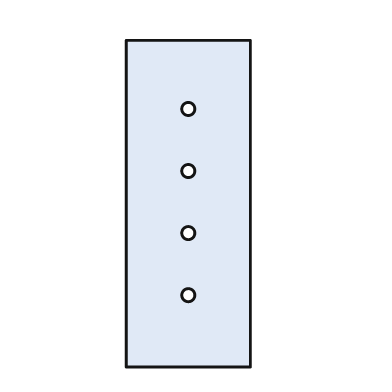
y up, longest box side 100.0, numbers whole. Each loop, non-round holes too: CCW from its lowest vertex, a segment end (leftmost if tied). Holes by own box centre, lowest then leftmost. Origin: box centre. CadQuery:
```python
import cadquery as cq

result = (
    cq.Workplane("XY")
    .moveTo(-19.0, -50.0)
    .lineTo(19.0, -50.0)
    .lineTo(19.0, 50.0)
    .lineTo(-19.0, 50.0)
    .close()
    .moveTo(0.0, -28.0)
    .circle(2.0)
    .moveTo(0.0, -9.0)
    .circle(2.0)
    .moveTo(0.0, 10.0)
    .circle(2.0)
    .moveTo(0.0, 29.0)
    .circle(2.0)
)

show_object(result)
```